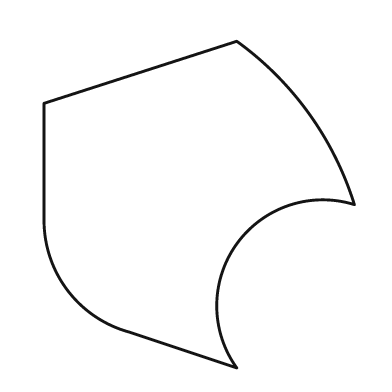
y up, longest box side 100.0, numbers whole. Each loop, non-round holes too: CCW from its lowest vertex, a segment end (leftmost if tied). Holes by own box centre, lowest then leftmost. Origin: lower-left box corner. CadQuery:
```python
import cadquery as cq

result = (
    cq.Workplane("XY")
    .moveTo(59.0, 0.0)
    .threePointArc((59.0, 38.0), (95.0, 50.0))
    .threePointArc((81.0, 78.0), (59.0, 100.0))
    .lineTo(0.0, 81.0)
    .lineTo(0.0, 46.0)
    .threePointArc((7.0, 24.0), (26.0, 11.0))
    .close()
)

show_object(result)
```